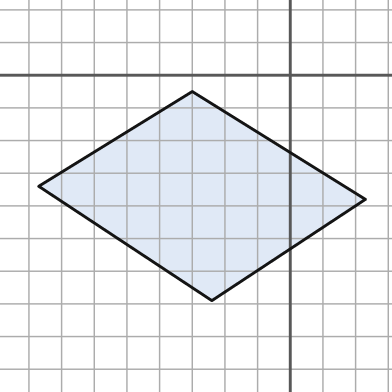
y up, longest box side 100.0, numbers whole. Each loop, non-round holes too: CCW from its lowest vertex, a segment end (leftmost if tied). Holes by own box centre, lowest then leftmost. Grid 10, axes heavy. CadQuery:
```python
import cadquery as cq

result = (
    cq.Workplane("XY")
    .moveTo(-24.0, -69.0)
    .lineTo(23.0, -38.0)
    .lineTo(-30.0, -5.0)
    .lineTo(-77.0, -34.0)
    .close()
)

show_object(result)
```